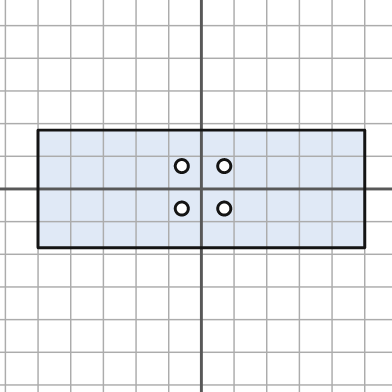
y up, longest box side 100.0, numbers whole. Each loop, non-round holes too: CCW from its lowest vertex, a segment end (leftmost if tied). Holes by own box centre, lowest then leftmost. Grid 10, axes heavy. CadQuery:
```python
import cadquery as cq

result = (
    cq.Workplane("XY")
    .moveTo(-50.0, -18.0)
    .lineTo(50.0, -18.0)
    .lineTo(50.0, 18.0)
    .lineTo(-50.0, 18.0)
    .close()
    .moveTo(-6.0, -6.0)
    .circle(2.0)
    .moveTo(7.0, -6.0)
    .circle(2.0)
    .moveTo(-6.0, 7.0)
    .circle(2.0)
    .moveTo(7.0, 7.0)
    .circle(2.0)
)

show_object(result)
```